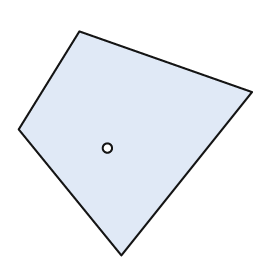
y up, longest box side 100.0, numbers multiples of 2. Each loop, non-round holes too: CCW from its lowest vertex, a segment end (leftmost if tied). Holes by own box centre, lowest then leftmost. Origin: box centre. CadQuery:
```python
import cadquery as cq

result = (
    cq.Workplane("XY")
    .moveTo(-6.0, -48.0)
    .lineTo(50.0, 22.0)
    .lineTo(-24.0, 48.0)
    .lineTo(-50.0, 6.0)
    .close()
    .moveTo(-12.0, -2.0)
    .circle(2.0)
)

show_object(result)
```